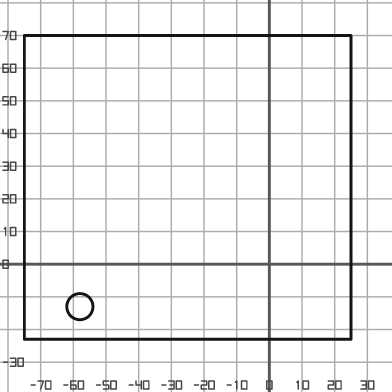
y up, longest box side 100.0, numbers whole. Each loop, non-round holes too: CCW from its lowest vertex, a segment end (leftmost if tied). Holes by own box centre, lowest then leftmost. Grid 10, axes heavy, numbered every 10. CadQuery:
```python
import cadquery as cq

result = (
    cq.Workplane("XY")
    .moveTo(-75.0, -23.0)
    .lineTo(25.0, -23.0)
    .lineTo(25.0, 70.0)
    .lineTo(-75.0, 70.0)
    .close()
    .moveTo(-58.0, -13.0)
    .circle(4.0)
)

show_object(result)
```